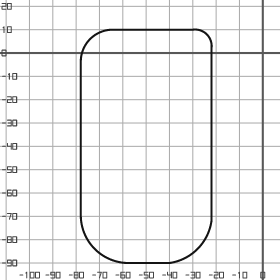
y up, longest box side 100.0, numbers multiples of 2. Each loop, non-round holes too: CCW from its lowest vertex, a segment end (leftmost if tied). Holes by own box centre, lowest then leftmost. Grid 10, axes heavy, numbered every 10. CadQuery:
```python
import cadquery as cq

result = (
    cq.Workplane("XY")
    .moveTo(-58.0, -90.0)
    .lineTo(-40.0, -90.0)
    .threePointArc((-28.0, -84.0), (-22.0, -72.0))
    .lineTo(-22.0, 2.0)
    .threePointArc((-24.0, 8.0), (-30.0, 10.0))
    .lineTo(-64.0, 10.0)
    .threePointArc((-74.0, 6.0), (-78.0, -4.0))
    .lineTo(-78.0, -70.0)
    .threePointArc((-72.0, -84.0), (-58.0, -90.0))
    .close()
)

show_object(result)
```